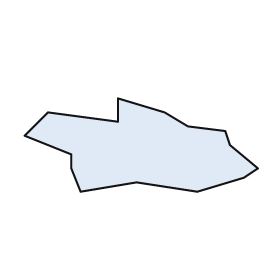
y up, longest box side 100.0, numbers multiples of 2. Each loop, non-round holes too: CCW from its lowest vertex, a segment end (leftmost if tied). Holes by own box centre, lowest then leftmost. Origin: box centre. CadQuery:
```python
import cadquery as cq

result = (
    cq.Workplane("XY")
    .moveTo(-26.0, -20.0)
    .lineTo(-2.0, -16.0)
    .lineTo(24.0, -20.0)
    .lineTo(44.0, -14.0)
    .lineTo(50.0, -10.0)
    .lineTo(38.0, 0.0)
    .lineTo(36.0, 6.0)
    .lineTo(20.0, 8.0)
    .lineTo(10.0, 14.0)
    .lineTo(-10.0, 20.0)
    .lineTo(-10.0, 10.0)
    .lineTo(-40.0, 14.0)
    .lineTo(-50.0, 4.0)
    .lineTo(-30.0, -4.0)
    .lineTo(-30.0, -10.0)
    .close()
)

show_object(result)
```